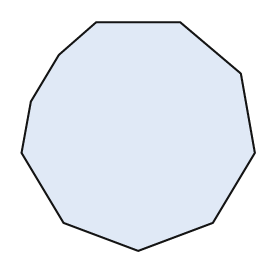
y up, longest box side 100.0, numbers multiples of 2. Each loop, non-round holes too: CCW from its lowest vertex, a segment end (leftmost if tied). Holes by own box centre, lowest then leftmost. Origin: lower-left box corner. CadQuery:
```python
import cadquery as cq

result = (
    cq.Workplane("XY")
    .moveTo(50.0, 0.0)
    .lineTo(82.0, 12.0)
    .lineTo(100.0, 42.0)
    .lineTo(94.0, 76.0)
    .lineTo(68.0, 98.0)
    .lineTo(32.0, 98.0)
    .lineTo(16.0, 84.0)
    .lineTo(4.0, 64.0)
    .lineTo(0.0, 42.0)
    .lineTo(18.0, 12.0)
    .close()
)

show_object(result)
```